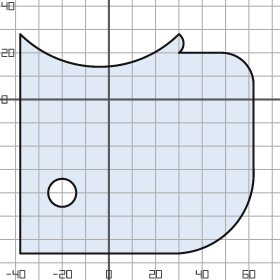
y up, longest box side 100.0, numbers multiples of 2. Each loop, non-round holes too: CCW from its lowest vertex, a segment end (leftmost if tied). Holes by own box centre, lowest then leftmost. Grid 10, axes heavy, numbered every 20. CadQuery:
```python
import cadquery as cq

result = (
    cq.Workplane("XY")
    .moveTo(-38.0, -66.0)
    .lineTo(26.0, -66.0)
    .threePointArc((52.0, -56.0), (62.0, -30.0))
    .lineTo(62.0, 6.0)
    .threePointArc((58.0, 16.0), (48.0, 20.0))
    .lineTo(30.0, 20.0)
    .threePointArc((32.0, 24.0), (30.0, 28.0))
    .threePointArc((-4.0, 14.0), (-38.0, 28.0))
    .close()
    .moveTo(-20.0, -40.0)
    .circle(6.0)
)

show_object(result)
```